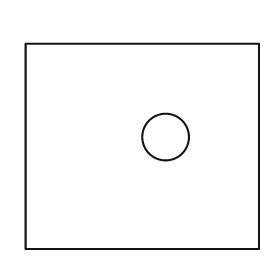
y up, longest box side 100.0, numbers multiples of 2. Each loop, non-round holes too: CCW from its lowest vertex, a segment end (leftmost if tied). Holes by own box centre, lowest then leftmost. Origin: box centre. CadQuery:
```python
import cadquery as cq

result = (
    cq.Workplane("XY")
    .moveTo(-50.0, -44.0)
    .lineTo(50.0, -44.0)
    .lineTo(50.0, 44.0)
    .lineTo(-50.0, 44.0)
    .close()
    .moveTo(10.0, 4.0)
    .circle(10.0)
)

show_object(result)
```